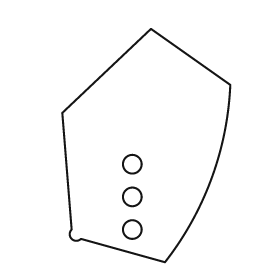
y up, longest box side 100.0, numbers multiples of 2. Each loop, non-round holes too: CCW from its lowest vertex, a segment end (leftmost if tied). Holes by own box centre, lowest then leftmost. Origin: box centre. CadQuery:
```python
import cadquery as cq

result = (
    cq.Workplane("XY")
    .moveTo(8.0, -50.0)
    .threePointArc((28.0, -14.0), (36.0, 26.0))
    .lineTo(2.0, 50.0)
    .lineTo(-36.0, 14.0)
    .lineTo(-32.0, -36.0)
    .threePointArc((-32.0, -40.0), (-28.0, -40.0))
    .close()
    .moveTo(-6.0, -36.0)
    .circle(4.0)
    .moveTo(-6.0, -22.0)
    .circle(4.0)
    .moveTo(-6.0, -8.0)
    .circle(4.0)
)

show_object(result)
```